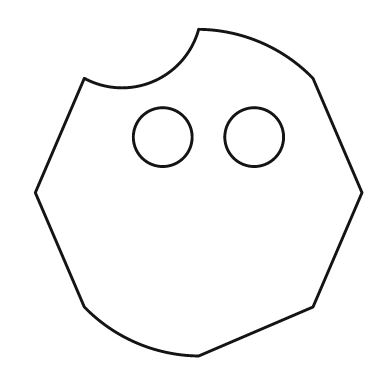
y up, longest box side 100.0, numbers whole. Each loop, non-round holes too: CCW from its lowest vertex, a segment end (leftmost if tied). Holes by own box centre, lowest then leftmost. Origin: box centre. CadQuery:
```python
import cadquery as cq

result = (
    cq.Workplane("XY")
    .moveTo(0.0, -50.0)
    .lineTo(35.0, -35.0)
    .lineTo(50.0, 0.0)
    .lineTo(35.0, 35.0)
    .threePointArc((19.0, 46.0), (0.0, 50.0))
    .threePointArc((-14.0, 34.0), (-35.0, 35.0))
    .lineTo(-50.0, 0.0)
    .lineTo(-35.0, -35.0)
    .threePointArc((-19.0, -46.0), (0.0, -50.0))
    .close()
    .moveTo(-11.0, 17.0)
    .circle(9.0)
    .moveTo(17.0, 17.0)
    .circle(9.0)
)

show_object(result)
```